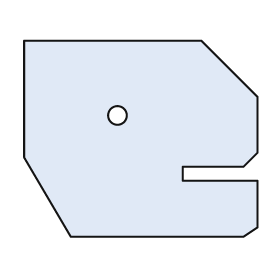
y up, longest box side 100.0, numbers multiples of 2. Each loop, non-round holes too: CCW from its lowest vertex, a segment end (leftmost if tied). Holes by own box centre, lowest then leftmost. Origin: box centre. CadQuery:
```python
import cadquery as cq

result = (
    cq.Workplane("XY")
    .moveTo(-30.0, -42.0)
    .lineTo(44.0, -42.0)
    .lineTo(50.0, -38.0)
    .lineTo(50.0, -18.0)
    .lineTo(18.0, -18.0)
    .lineTo(18.0, -12.0)
    .lineTo(44.0, -12.0)
    .lineTo(50.0, -6.0)
    .lineTo(50.0, 18.0)
    .lineTo(26.0, 42.0)
    .lineTo(-50.0, 42.0)
    .lineTo(-50.0, -8.0)
    .close()
    .moveTo(-10.0, 10.0)
    .circle(4.0)
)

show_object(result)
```